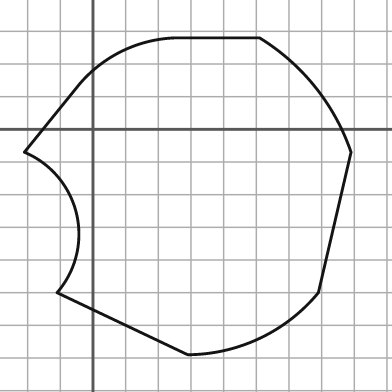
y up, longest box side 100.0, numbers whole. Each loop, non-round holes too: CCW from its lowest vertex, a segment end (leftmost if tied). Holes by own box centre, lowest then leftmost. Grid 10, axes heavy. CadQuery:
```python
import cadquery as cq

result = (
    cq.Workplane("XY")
    .moveTo(29.0, -69.0)
    .threePointArc((51.0, -64.0), (69.0, -50.0))
    .lineTo(79.0, -7.0)
    .threePointArc((68.0, 13.0), (51.0, 28.0))
    .lineTo(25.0, 28.0)
    .threePointArc((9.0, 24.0), (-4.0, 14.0))
    .lineTo(-21.0, -7.0)
    .threePointArc((-5.0, -26.0), (-11.0, -50.0))
    .close()
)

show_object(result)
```